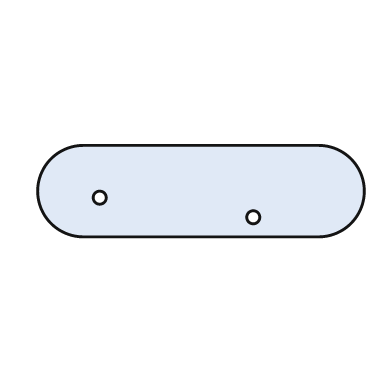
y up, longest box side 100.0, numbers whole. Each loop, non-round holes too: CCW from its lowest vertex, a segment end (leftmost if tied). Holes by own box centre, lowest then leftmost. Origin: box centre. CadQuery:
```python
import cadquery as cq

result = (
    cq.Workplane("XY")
    .moveTo(-36.0, -14.0)
    .lineTo(36.0, -14.0)
    .threePointArc((50.0, 0.0), (36.0, 14.0))
    .lineTo(-36.0, 14.0)
    .threePointArc((-50.0, 0.0), (-36.0, -14.0))
    .close()
    .moveTo(16.0, -8.0)
    .circle(2.0)
    .moveTo(-31.0, -2.0)
    .circle(2.0)
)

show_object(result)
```